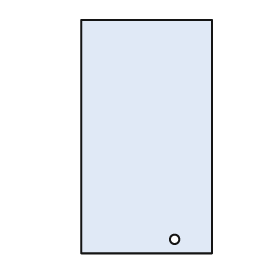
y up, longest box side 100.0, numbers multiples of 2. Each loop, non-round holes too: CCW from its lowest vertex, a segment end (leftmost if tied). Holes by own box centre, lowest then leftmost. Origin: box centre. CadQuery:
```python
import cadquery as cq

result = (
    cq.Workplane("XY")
    .moveTo(-28.0, -50.0)
    .lineTo(28.0, -50.0)
    .lineTo(28.0, 50.0)
    .lineTo(-28.0, 50.0)
    .close()
    .moveTo(12.0, -44.0)
    .circle(2.0)
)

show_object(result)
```